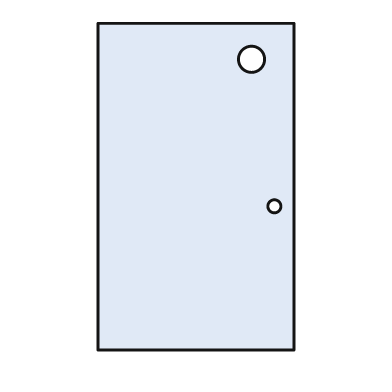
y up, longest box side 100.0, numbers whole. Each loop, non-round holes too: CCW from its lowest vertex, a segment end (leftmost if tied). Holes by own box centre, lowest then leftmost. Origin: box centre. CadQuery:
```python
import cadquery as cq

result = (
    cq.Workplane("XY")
    .moveTo(-30.0, -50.0)
    .lineTo(30.0, -50.0)
    .lineTo(30.0, 50.0)
    .lineTo(-30.0, 50.0)
    .close()
    .moveTo(24.0, -6.0)
    .circle(2.0)
    .moveTo(17.0, 39.0)
    .circle(4.0)
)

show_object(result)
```